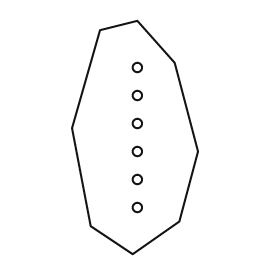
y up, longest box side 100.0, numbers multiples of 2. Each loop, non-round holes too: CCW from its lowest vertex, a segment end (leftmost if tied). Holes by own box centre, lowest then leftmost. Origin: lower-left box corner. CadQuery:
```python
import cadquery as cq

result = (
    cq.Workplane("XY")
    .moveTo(26.0, 0.0)
    .lineTo(46.0, 14.0)
    .lineTo(54.0, 44.0)
    .lineTo(44.0, 82.0)
    .lineTo(28.0, 100.0)
    .lineTo(12.0, 96.0)
    .lineTo(0.0, 54.0)
    .lineTo(8.0, 12.0)
    .close()
    .moveTo(28.0, 20.0)
    .circle(2.0)
    .moveTo(28.0, 32.0)
    .circle(2.0)
    .moveTo(28.0, 44.0)
    .circle(2.0)
    .moveTo(28.0, 56.0)
    .circle(2.0)
    .moveTo(28.0, 68.0)
    .circle(2.0)
    .moveTo(28.0, 80.0)
    .circle(2.0)
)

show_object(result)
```